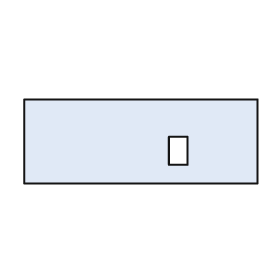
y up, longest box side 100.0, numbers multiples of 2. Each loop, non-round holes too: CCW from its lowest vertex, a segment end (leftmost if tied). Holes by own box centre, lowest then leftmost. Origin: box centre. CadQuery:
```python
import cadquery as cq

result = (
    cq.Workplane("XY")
    .moveTo(-50.0, -18.0)
    .lineTo(50.0, -18.0)
    .lineTo(50.0, 18.0)
    .lineTo(-50.0, 18.0)
    .close()
    .moveTo(12.0, -10.0)
    .lineTo(20.0, -10.0)
    .lineTo(20.0, 2.0)
    .lineTo(12.0, 2.0)
    .close()
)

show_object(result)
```